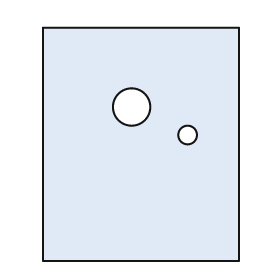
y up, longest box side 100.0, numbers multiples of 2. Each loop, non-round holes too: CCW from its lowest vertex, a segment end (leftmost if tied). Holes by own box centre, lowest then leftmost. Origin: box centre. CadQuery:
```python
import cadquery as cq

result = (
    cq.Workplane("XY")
    .moveTo(-42.0, -50.0)
    .lineTo(42.0, -50.0)
    .lineTo(42.0, 50.0)
    .lineTo(-42.0, 50.0)
    .close()
    .moveTo(20.0, 4.0)
    .circle(4.0)
    .moveTo(-4.0, 16.0)
    .circle(8.0)
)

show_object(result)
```